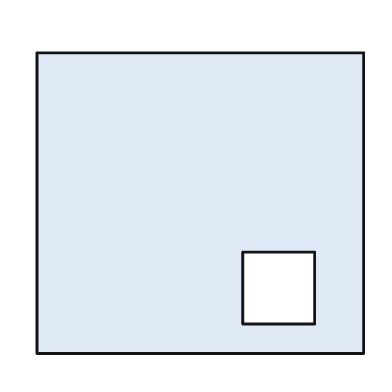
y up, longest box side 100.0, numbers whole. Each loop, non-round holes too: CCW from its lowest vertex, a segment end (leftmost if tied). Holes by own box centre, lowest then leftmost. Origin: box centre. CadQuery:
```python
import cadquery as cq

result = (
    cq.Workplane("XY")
    .moveTo(-50.0, -46.0)
    .lineTo(50.0, -46.0)
    .lineTo(50.0, 46.0)
    .lineTo(-50.0, 46.0)
    .close()
    .moveTo(13.0, -37.0)
    .lineTo(35.0, -37.0)
    .lineTo(35.0, -15.0)
    .lineTo(13.0, -15.0)
    .close()
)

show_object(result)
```